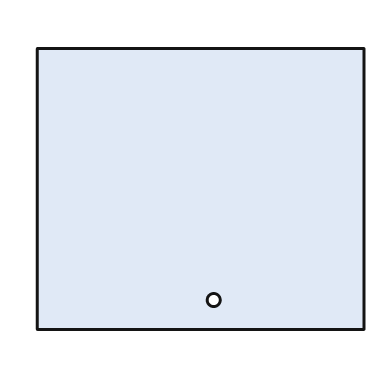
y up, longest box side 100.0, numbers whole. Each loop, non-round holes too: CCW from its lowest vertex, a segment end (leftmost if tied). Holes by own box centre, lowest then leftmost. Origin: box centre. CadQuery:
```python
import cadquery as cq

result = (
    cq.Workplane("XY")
    .moveTo(-50.0, -43.0)
    .lineTo(50.0, -43.0)
    .lineTo(50.0, 43.0)
    .lineTo(-50.0, 43.0)
    .close()
    .moveTo(4.0, -34.0)
    .circle(2.0)
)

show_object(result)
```